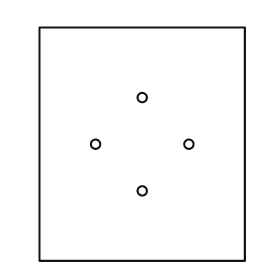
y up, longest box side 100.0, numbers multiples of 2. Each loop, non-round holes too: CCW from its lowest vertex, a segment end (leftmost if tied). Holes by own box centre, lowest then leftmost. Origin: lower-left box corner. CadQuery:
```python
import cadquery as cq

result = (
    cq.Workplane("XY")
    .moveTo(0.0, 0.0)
    .lineTo(88.0, 0.0)
    .lineTo(88.0, 100.0)
    .lineTo(0.0, 100.0)
    .close()
    .moveTo(44.0, 30.0)
    .circle(2.0)
    .moveTo(24.0, 50.0)
    .circle(2.0)
    .moveTo(64.0, 50.0)
    .circle(2.0)
    .moveTo(44.0, 70.0)
    .circle(2.0)
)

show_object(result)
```